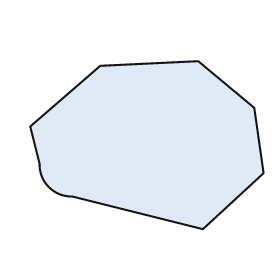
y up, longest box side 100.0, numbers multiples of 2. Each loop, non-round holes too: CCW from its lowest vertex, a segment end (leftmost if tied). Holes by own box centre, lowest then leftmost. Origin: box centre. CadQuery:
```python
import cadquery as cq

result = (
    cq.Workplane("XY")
    .moveTo(24.0, -36.0)
    .lineTo(50.0, -12.0)
    .lineTo(46.0, 16.0)
    .lineTo(22.0, 36.0)
    .lineTo(-20.0, 34.0)
    .lineTo(-50.0, 8.0)
    .lineTo(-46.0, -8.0)
    .threePointArc((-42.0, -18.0), (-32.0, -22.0))
    .close()
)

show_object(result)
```